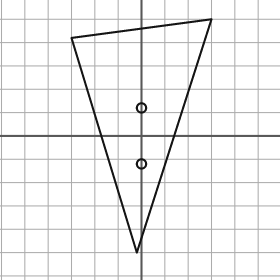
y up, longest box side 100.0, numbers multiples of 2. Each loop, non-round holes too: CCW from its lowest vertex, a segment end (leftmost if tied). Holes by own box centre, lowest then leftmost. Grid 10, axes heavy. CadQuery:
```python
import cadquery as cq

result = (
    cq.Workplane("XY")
    .moveTo(-2.0, -50.0)
    .lineTo(30.0, 50.0)
    .lineTo(-30.0, 42.0)
    .close()
    .moveTo(0.0, -12.0)
    .circle(2.0)
    .moveTo(0.0, 12.0)
    .circle(2.0)
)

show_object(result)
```